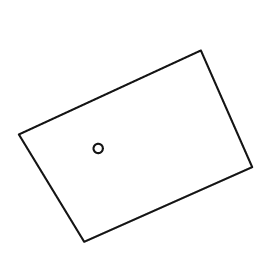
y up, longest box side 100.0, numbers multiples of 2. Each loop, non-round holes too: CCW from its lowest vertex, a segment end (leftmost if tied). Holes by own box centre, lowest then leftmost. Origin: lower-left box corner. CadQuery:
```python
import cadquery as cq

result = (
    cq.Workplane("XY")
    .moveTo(28.0, 0.0)
    .lineTo(100.0, 32.0)
    .lineTo(78.0, 82.0)
    .lineTo(0.0, 46.0)
    .close()
    .moveTo(34.0, 40.0)
    .circle(2.0)
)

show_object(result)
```